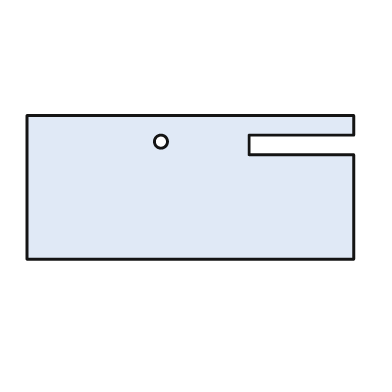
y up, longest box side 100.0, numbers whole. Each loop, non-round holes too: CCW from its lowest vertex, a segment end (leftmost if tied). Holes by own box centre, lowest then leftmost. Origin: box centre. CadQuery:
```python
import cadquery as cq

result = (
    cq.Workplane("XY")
    .moveTo(-50.0, -22.0)
    .lineTo(50.0, -22.0)
    .lineTo(50.0, 10.0)
    .lineTo(18.0, 10.0)
    .lineTo(18.0, 16.0)
    .lineTo(50.0, 16.0)
    .lineTo(50.0, 22.0)
    .lineTo(-50.0, 22.0)
    .close()
    .moveTo(-9.0, 14.0)
    .circle(2.0)
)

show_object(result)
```